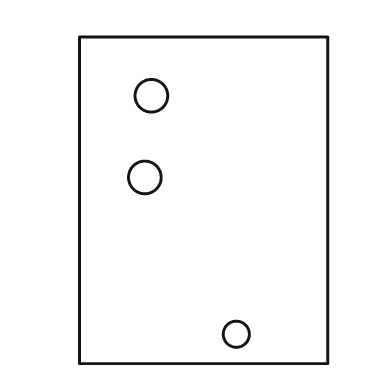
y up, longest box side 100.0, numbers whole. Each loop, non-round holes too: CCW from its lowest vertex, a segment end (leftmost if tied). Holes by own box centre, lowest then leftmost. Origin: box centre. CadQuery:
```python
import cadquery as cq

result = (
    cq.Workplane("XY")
    .moveTo(-38.0, -50.0)
    .lineTo(38.0, -50.0)
    .lineTo(38.0, 50.0)
    .lineTo(-38.0, 50.0)
    .close()
    .moveTo(10.0, -41.0)
    .circle(4.0)
    .moveTo(-18.0, 7.0)
    .circle(5.0)
    .moveTo(-16.0, 32.0)
    .circle(5.0)
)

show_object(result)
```